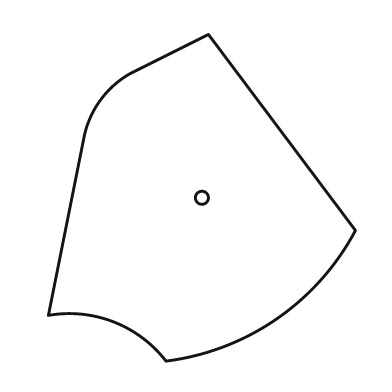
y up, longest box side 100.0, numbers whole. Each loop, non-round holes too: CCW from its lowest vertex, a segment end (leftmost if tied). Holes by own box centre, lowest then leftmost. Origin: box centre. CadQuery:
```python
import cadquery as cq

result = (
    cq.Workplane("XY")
    .moveTo(-11.0, -50.0)
    .threePointArc((23.0, -37.0), (47.0, -10.0))
    .lineTo(2.0, 50.0)
    .lineTo(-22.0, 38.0)
    .threePointArc((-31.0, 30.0), (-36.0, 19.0))
    .lineTo(-47.0, -36.0)
    .threePointArc((-27.0, -38.0), (-11.0, -50.0))
    .close()
    .moveTo(0.0, 0.0)
    .circle(2.0)
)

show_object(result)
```